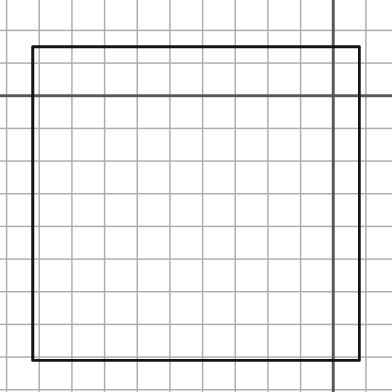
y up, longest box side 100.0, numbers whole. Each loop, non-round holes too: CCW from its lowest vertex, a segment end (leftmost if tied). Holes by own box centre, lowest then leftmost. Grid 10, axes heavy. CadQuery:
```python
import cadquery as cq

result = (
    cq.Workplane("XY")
    .moveTo(-92.0, -81.0)
    .lineTo(8.0, -81.0)
    .lineTo(8.0, 15.0)
    .lineTo(-92.0, 15.0)
    .close()
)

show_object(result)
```